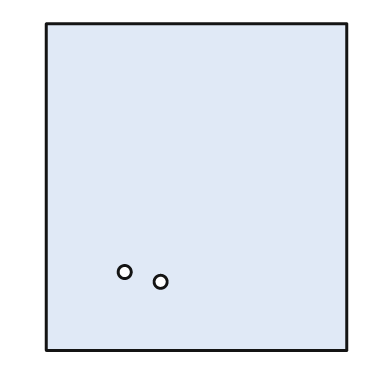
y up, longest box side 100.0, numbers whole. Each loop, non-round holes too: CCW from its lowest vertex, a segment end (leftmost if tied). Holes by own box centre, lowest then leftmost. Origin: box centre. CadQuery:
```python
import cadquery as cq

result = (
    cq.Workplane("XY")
    .moveTo(-46.0, -50.0)
    .lineTo(46.0, -50.0)
    .lineTo(46.0, 50.0)
    .lineTo(-46.0, 50.0)
    .close()
    .moveTo(-11.0, -29.0)
    .circle(2.0)
    .moveTo(-22.0, -26.0)
    .circle(2.0)
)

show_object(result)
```